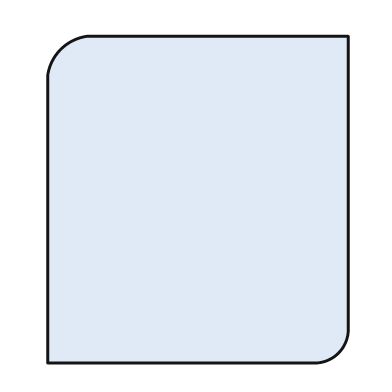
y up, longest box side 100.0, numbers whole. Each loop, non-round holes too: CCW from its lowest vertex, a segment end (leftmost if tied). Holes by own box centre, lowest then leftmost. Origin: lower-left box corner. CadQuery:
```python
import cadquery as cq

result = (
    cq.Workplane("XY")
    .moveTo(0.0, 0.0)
    .lineTo(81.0, 0.0)
    .threePointArc((89.0, 3.0), (92.0, 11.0))
    .lineTo(92.0, 100.0)
    .lineTo(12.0, 100.0)
    .threePointArc((4.0, 96.0), (0.0, 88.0))
    .close()
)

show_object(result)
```